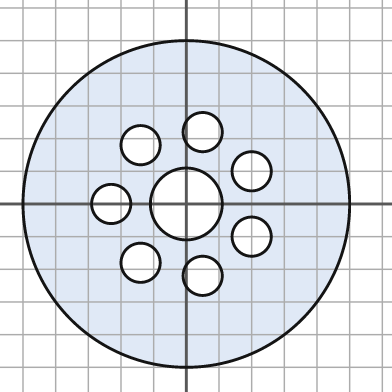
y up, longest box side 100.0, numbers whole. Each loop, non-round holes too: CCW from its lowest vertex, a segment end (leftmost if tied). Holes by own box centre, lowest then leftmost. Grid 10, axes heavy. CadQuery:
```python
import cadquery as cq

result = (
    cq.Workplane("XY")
    .moveTo(0.0, 0.0)
    .circle(50.0)
    .moveTo(5.0, -22.0)
    .circle(6.0)
    .moveTo(-14.0, -18.0)
    .circle(6.0)
    .moveTo(20.0, -10.0)
    .circle(6.0)
    .moveTo(-23.0, 0.0)
    .circle(6.0)
    .moveTo(0.0, 0.0)
    .circle(11.0)
    .moveTo(20.0, 10.0)
    .circle(6.0)
    .moveTo(-14.0, 18.0)
    .circle(6.0)
    .moveTo(5.0, 22.0)
    .circle(6.0)
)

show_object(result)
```